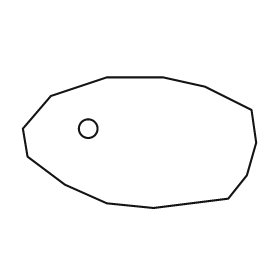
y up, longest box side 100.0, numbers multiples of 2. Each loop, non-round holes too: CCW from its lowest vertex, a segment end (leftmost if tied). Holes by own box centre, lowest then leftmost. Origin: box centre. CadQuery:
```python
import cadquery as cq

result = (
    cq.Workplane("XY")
    .moveTo(6.0, -28.0)
    .lineTo(38.0, -24.0)
    .lineTo(46.0, -14.0)
    .lineTo(50.0, 0.0)
    .lineTo(48.0, 14.0)
    .lineTo(28.0, 24.0)
    .lineTo(10.0, 28.0)
    .lineTo(-14.0, 28.0)
    .lineTo(-38.0, 20.0)
    .lineTo(-50.0, 6.0)
    .lineTo(-48.0, -6.0)
    .lineTo(-32.0, -18.0)
    .lineTo(-14.0, -26.0)
    .close()
    .moveTo(-22.0, 6.0)
    .circle(4.0)
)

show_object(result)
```